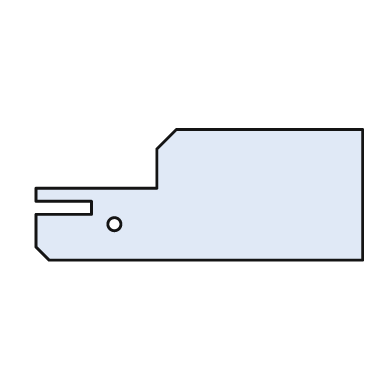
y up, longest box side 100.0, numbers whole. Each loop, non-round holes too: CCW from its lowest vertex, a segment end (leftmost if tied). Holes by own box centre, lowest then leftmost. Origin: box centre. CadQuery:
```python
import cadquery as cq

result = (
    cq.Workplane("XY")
    .moveTo(-46.0, -20.0)
    .lineTo(50.0, -20.0)
    .lineTo(50.0, 20.0)
    .lineTo(-7.0, 20.0)
    .lineTo(-13.0, 14.0)
    .lineTo(-13.0, 2.0)
    .lineTo(-50.0, 2.0)
    .lineTo(-50.0, -2.0)
    .lineTo(-33.0, -2.0)
    .lineTo(-33.0, -6.0)
    .lineTo(-50.0, -6.0)
    .lineTo(-50.0, -16.0)
    .close()
    .moveTo(-26.0, -9.0)
    .circle(2.0)
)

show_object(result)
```